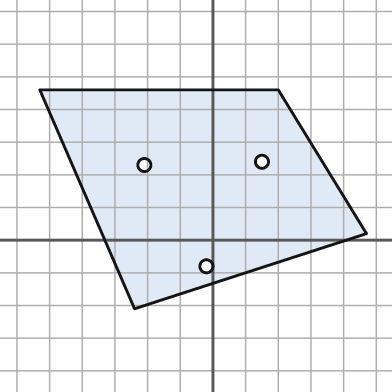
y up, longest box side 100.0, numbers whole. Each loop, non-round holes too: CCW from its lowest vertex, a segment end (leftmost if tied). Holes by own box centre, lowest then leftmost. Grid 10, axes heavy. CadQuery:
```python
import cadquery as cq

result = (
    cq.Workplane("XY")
    .moveTo(-24.0, -21.0)
    .lineTo(47.0, 2.0)
    .lineTo(20.0, 46.0)
    .lineTo(-53.0, 46.0)
    .close()
    .moveTo(-2.0, -8.0)
    .circle(2.0)
    .moveTo(-21.0, 23.0)
    .circle(2.0)
    .moveTo(15.0, 24.0)
    .circle(2.0)
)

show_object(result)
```